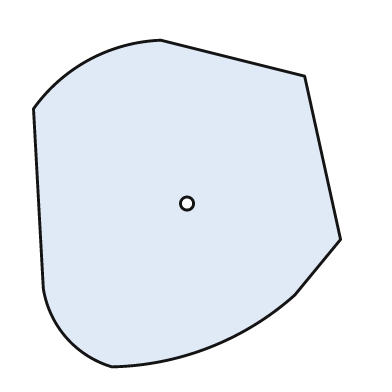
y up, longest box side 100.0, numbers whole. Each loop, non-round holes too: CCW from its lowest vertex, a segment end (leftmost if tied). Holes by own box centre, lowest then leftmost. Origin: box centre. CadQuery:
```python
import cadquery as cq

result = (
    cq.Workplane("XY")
    .moveTo(-23.0, -50.0)
    .threePointArc((7.0, -44.0), (33.0, -28.0))
    .lineTo(47.0, -11.0)
    .lineTo(36.0, 39.0)
    .lineTo(-8.0, 50.0)
    .threePointArc((-30.0, 44.0), (-47.0, 29.0))
    .lineTo(-44.0, -26.0)
    .threePointArc((-37.0, -41.0), (-23.0, -50.0))
    .close()
    .moveTo(0.0, 0.0)
    .circle(2.0)
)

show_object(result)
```